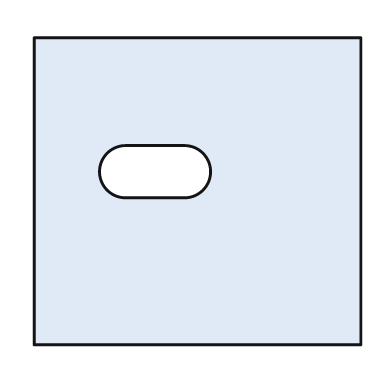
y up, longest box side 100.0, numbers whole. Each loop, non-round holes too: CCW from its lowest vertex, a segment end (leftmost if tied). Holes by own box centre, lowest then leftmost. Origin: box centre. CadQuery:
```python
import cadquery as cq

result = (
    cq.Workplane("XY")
    .moveTo(-50.0, -47.0)
    .lineTo(50.0, -47.0)
    .lineTo(50.0, 47.0)
    .lineTo(-50.0, 47.0)
    .close()
    .moveTo(-22.0, -2.0)
    .lineTo(-4.0, -2.0)
    .threePointArc((4.0, 6.0), (-4.0, 14.0))
    .lineTo(-22.0, 14.0)
    .threePointArc((-30.0, 6.0), (-22.0, -2.0))
    .close()
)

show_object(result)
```